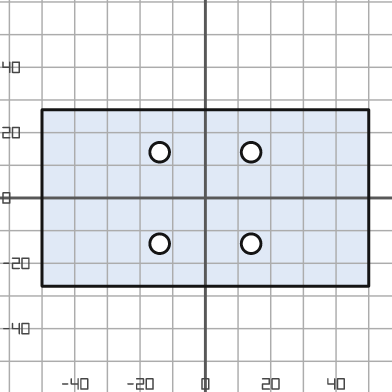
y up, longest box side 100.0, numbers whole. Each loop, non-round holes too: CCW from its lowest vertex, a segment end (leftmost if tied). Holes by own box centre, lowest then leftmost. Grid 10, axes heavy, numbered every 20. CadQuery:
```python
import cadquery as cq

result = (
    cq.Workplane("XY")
    .moveTo(-50.0, -27.0)
    .lineTo(50.0, -27.0)
    .lineTo(50.0, 27.0)
    .lineTo(-50.0, 27.0)
    .close()
    .moveTo(-14.0, -14.0)
    .circle(3.0)
    .moveTo(14.0, -14.0)
    .circle(3.0)
    .moveTo(-14.0, 14.0)
    .circle(3.0)
    .moveTo(14.0, 14.0)
    .circle(3.0)
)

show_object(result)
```